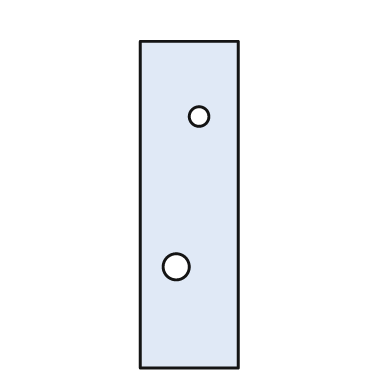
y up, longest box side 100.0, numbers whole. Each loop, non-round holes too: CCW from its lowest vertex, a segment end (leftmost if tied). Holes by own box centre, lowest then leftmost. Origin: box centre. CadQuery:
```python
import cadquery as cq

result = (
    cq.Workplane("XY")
    .moveTo(-15.0, -50.0)
    .lineTo(15.0, -50.0)
    .lineTo(15.0, 50.0)
    .lineTo(-15.0, 50.0)
    .close()
    .moveTo(-4.0, -19.0)
    .circle(4.0)
    .moveTo(3.0, 27.0)
    .circle(3.0)
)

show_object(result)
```